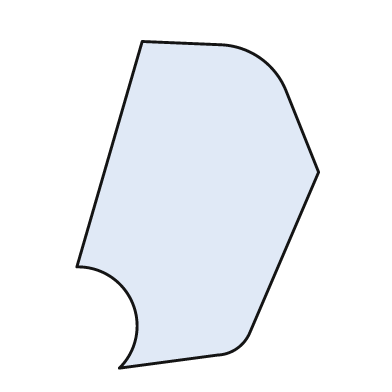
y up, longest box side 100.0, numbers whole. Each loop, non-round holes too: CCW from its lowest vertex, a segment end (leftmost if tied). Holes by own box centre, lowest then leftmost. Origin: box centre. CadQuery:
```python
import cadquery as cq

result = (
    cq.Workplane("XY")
    .moveTo(-24.0, -50.0)
    .lineTo(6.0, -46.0)
    .threePointArc((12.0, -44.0), (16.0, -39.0))
    .lineTo(37.0, 10.0)
    .lineTo(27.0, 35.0)
    .threePointArc((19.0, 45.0), (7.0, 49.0))
    .lineTo(-17.0, 50.0)
    .lineTo(-37.0, -19.0)
    .threePointArc((-20.0, -30.0), (-24.0, -50.0))
    .close()
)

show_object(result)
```